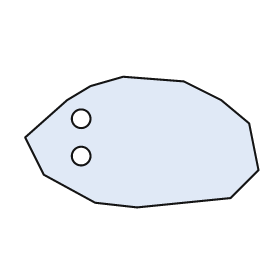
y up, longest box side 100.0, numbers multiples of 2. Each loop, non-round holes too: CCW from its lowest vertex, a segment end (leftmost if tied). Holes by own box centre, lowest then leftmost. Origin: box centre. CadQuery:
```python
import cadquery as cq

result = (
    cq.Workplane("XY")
    .moveTo(-2.0, -28.0)
    .lineTo(38.0, -24.0)
    .lineTo(50.0, -12.0)
    .lineTo(46.0, 8.0)
    .lineTo(34.0, 18.0)
    .lineTo(18.0, 26.0)
    .lineTo(-8.0, 28.0)
    .lineTo(-22.0, 24.0)
    .lineTo(-32.0, 18.0)
    .lineTo(-50.0, 2.0)
    .lineTo(-42.0, -14.0)
    .lineTo(-20.0, -26.0)
    .close()
    .moveTo(-26.0, -6.0)
    .circle(4.0)
    .moveTo(-26.0, 10.0)
    .circle(4.0)
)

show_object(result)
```